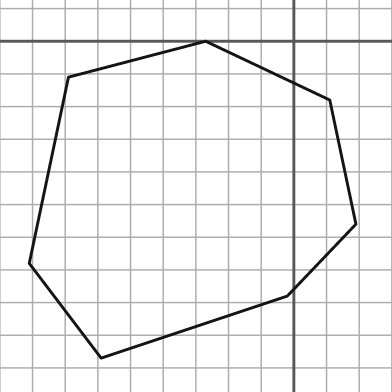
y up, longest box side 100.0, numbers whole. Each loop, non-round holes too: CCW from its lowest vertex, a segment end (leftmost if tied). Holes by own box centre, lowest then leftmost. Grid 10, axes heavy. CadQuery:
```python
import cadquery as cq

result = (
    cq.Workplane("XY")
    .moveTo(-59.0, -97.0)
    .lineTo(-2.0, -78.0)
    .lineTo(19.0, -56.0)
    .lineTo(11.0, -18.0)
    .lineTo(-27.0, 0.0)
    .lineTo(-69.0, -11.0)
    .lineTo(-81.0, -68.0)
    .close()
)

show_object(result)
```